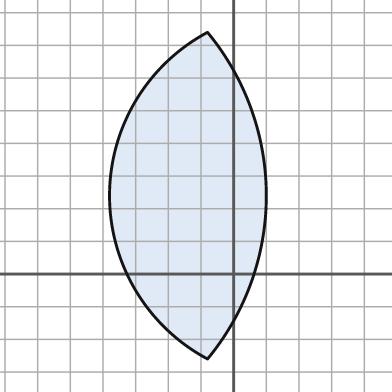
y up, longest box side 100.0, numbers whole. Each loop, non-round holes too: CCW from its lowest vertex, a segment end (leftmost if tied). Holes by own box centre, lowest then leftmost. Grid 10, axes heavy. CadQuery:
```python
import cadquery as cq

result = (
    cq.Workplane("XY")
    .moveTo(-8.0, -26.0)
    .threePointArc((10.0, 24.0), (-8.0, 74.0))
    .threePointArc((-38.0, 24.0), (-8.0, -26.0))
    .close()
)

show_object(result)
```